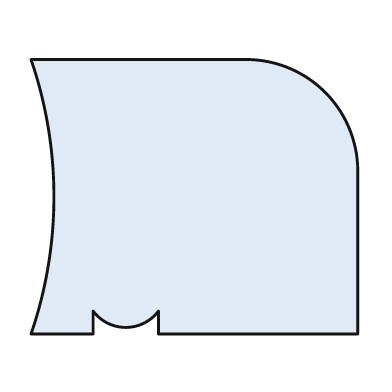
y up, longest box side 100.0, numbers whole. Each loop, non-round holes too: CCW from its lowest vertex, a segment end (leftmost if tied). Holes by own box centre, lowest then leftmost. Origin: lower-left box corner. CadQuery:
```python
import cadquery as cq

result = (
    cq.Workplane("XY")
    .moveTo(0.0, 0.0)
    .lineTo(19.0, 0.0)
    .lineTo(19.0, 7.0)
    .threePointArc((29.0, 2.0), (39.0, 7.0))
    .lineTo(39.0, 0.0)
    .lineTo(100.0, 0.0)
    .lineTo(100.0, 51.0)
    .threePointArc((90.0, 74.0), (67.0, 84.0))
    .lineTo(0.0, 84.0)
    .threePointArc((7.0, 42.0), (0.0, 0.0))
    .close()
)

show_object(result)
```